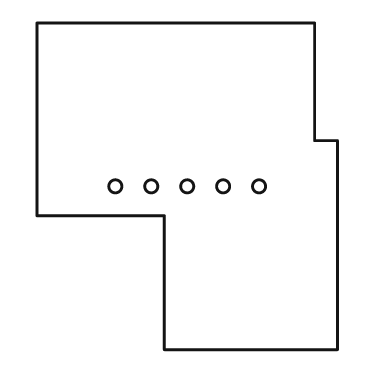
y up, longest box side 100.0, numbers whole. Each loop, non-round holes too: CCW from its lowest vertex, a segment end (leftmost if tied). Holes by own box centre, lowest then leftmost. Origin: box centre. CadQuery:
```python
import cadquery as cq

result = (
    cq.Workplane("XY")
    .moveTo(-7.0, -50.0)
    .lineTo(46.0, -50.0)
    .lineTo(46.0, 14.0)
    .lineTo(39.0, 14.0)
    .lineTo(39.0, 50.0)
    .lineTo(-46.0, 50.0)
    .lineTo(-46.0, -9.0)
    .lineTo(-7.0, -9.0)
    .close()
    .moveTo(-22.0, 0.0)
    .circle(2.0)
    .moveTo(-11.0, 0.0)
    .circle(2.0)
    .moveTo(0.0, 0.0)
    .circle(2.0)
    .moveTo(11.0, 0.0)
    .circle(2.0)
    .moveTo(22.0, 0.0)
    .circle(2.0)
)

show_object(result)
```